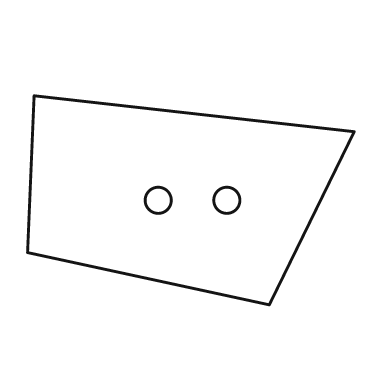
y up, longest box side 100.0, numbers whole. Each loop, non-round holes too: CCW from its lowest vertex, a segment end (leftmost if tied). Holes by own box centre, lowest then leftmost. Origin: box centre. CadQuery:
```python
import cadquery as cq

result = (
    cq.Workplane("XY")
    .moveTo(24.0, -32.0)
    .lineTo(50.0, 21.0)
    .lineTo(-48.0, 32.0)
    .lineTo(-50.0, -16.0)
    .close()
    .moveTo(-10.0, 0.0)
    .circle(4.0)
    .moveTo(11.0, 0.0)
    .circle(4.0)
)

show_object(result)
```